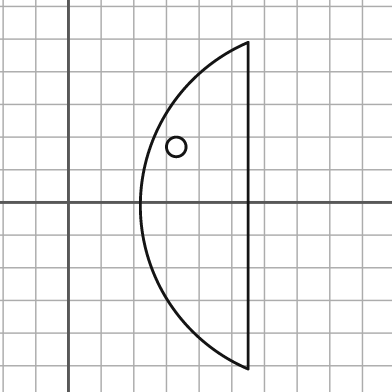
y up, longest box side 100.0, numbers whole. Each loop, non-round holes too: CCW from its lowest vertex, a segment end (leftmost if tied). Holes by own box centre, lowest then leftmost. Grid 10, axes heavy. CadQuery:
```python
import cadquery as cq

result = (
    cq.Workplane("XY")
    .moveTo(55.0, -51.0)
    .lineTo(55.0, 49.0)
    .threePointArc((22.0, -1.0), (55.0, -51.0))
    .close()
    .moveTo(33.0, 17.0)
    .circle(3.0)
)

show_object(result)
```